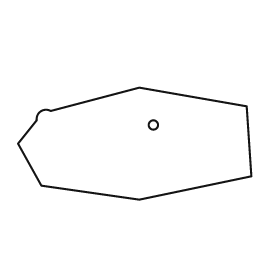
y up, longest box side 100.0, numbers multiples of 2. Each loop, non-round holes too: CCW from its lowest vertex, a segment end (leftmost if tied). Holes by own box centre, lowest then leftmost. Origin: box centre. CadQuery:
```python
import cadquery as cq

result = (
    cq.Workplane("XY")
    .moveTo(2.0, -24.0)
    .lineTo(50.0, -14.0)
    .lineTo(48.0, 16.0)
    .lineTo(2.0, 24.0)
    .lineTo(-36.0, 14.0)
    .threePointArc((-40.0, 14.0), (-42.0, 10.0))
    .lineTo(-50.0, 0.0)
    .lineTo(-40.0, -18.0)
    .close()
    .moveTo(8.0, 8.0)
    .circle(2.0)
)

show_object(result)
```